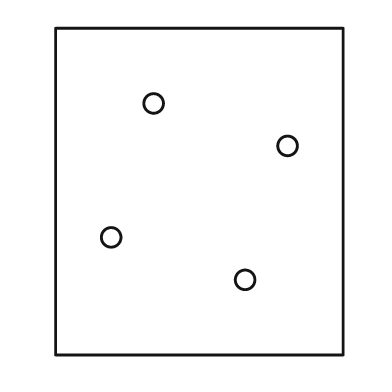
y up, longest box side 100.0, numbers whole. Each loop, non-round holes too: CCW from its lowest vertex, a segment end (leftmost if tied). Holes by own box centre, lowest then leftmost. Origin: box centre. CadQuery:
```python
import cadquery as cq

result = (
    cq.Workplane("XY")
    .moveTo(-44.0, -50.0)
    .lineTo(44.0, -50.0)
    .lineTo(44.0, 50.0)
    .lineTo(-44.0, 50.0)
    .close()
    .moveTo(14.0, -27.0)
    .circle(3.0)
    .moveTo(-27.0, -14.0)
    .circle(3.0)
    .moveTo(27.0, 14.0)
    .circle(3.0)
    .moveTo(-14.0, 27.0)
    .circle(3.0)
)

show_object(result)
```